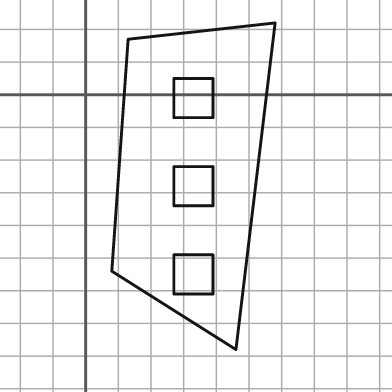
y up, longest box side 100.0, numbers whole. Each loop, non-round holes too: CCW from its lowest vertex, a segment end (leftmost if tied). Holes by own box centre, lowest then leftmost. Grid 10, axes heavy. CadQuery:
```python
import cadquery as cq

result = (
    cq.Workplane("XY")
    .moveTo(46.0, -78.0)
    .lineTo(58.0, 22.0)
    .lineTo(13.0, 17.0)
    .lineTo(8.0, -54.0)
    .close()
    .moveTo(27.0, -61.0)
    .lineTo(39.0, -61.0)
    .lineTo(39.0, -49.0)
    .lineTo(27.0, -49.0)
    .close()
    .moveTo(27.0, -34.0)
    .lineTo(39.0, -34.0)
    .lineTo(39.0, -22.0)
    .lineTo(27.0, -22.0)
    .close()
    .moveTo(27.0, -7.0)
    .lineTo(39.0, -7.0)
    .lineTo(39.0, 5.0)
    .lineTo(27.0, 5.0)
    .close()
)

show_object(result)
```